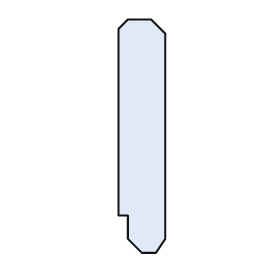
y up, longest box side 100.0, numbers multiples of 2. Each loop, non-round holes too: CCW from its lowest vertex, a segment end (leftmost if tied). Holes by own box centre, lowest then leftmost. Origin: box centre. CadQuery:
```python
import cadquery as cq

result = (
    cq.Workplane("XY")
    .moveTo(0.0, -50.0)
    .lineTo(6.0, -50.0)
    .lineTo(10.0, -44.0)
    .lineTo(10.0, 44.0)
    .lineTo(4.0, 50.0)
    .lineTo(-6.0, 50.0)
    .lineTo(-10.0, 46.0)
    .lineTo(-10.0, -34.0)
    .lineTo(-6.0, -34.0)
    .lineTo(-6.0, -44.0)
    .close()
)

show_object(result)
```